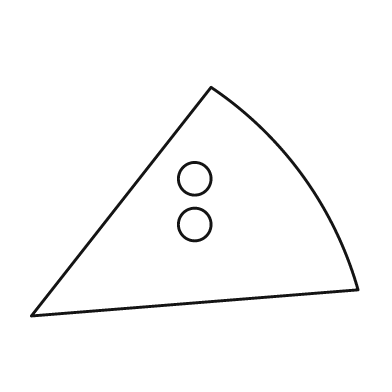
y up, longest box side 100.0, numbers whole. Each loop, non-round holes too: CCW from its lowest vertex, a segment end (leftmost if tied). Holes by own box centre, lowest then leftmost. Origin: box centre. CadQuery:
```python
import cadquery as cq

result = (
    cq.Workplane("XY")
    .moveTo(-50.0, -35.0)
    .lineTo(50.0, -27.0)
    .threePointArc((33.0, 8.0), (5.0, 35.0))
    .close()
    .moveTo(0.0, -7.0)
    .circle(5.0)
    .moveTo(0.0, 7.0)
    .circle(5.0)
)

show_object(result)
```